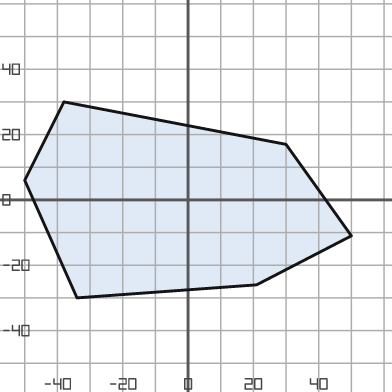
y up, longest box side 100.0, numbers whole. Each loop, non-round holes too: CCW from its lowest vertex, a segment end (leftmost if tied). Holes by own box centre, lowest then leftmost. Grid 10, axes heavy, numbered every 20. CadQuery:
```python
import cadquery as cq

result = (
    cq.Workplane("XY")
    .moveTo(-34.0, -30.0)
    .lineTo(21.0, -26.0)
    .lineTo(50.0, -11.0)
    .lineTo(30.0, 17.0)
    .lineTo(-38.0, 30.0)
    .lineTo(-50.0, 6.0)
    .close()
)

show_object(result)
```